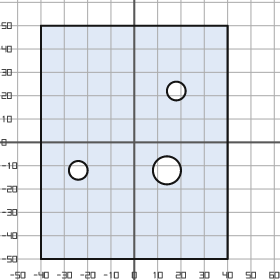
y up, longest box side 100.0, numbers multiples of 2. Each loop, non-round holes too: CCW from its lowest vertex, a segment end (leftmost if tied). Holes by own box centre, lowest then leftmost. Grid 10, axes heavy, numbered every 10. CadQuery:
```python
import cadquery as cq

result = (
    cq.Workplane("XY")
    .moveTo(-40.0, -50.0)
    .lineTo(40.0, -50.0)
    .lineTo(40.0, 50.0)
    .lineTo(-40.0, 50.0)
    .close()
    .moveTo(-24.0, -12.0)
    .circle(4.0)
    .moveTo(14.0, -12.0)
    .circle(6.0)
    .moveTo(18.0, 22.0)
    .circle(4.0)
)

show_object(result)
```